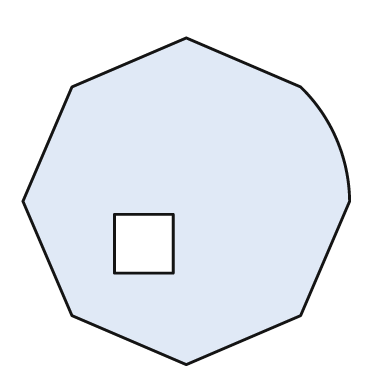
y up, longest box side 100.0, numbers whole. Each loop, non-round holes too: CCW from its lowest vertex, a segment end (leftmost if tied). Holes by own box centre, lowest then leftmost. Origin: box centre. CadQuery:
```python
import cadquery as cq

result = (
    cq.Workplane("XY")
    .moveTo(0.0, -50.0)
    .lineTo(35.0, -35.0)
    .lineTo(50.0, 0.0)
    .threePointArc((46.0, 19.0), (35.0, 35.0))
    .lineTo(0.0, 50.0)
    .lineTo(-35.0, 35.0)
    .lineTo(-50.0, 0.0)
    .lineTo(-35.0, -35.0)
    .close()
    .moveTo(-22.0, -22.0)
    .lineTo(-4.0, -22.0)
    .lineTo(-4.0, -4.0)
    .lineTo(-22.0, -4.0)
    .close()
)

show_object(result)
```